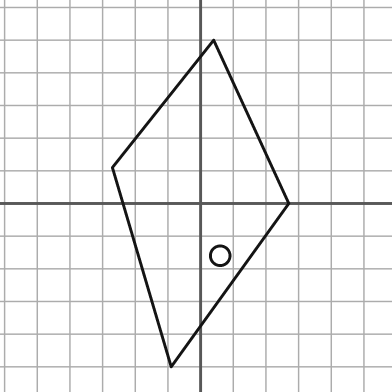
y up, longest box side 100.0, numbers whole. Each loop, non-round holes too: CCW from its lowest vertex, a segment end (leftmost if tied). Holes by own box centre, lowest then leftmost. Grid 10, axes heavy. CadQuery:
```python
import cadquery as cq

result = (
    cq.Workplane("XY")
    .moveTo(-9.0, -50.0)
    .lineTo(27.0, 0.0)
    .lineTo(4.0, 50.0)
    .lineTo(-27.0, 11.0)
    .close()
    .moveTo(6.0, -16.0)
    .circle(3.0)
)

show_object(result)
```